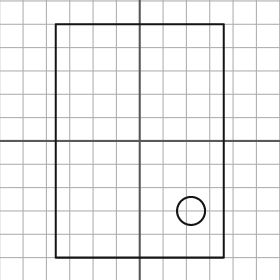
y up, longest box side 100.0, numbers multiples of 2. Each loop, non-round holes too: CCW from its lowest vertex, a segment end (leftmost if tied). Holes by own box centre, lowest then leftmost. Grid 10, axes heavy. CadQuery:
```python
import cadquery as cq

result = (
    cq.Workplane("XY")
    .moveTo(-36.0, -50.0)
    .lineTo(36.0, -50.0)
    .lineTo(36.0, 50.0)
    .lineTo(-36.0, 50.0)
    .close()
    .moveTo(22.0, -30.0)
    .circle(6.0)
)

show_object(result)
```